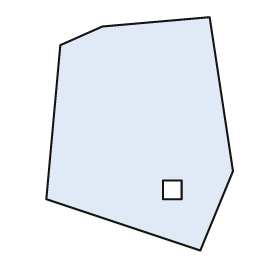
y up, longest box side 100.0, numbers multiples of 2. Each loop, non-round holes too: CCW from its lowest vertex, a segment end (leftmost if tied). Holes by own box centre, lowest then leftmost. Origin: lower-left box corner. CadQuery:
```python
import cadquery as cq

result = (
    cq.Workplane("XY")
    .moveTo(66.0, 0.0)
    .lineTo(80.0, 34.0)
    .lineTo(70.0, 100.0)
    .lineTo(24.0, 96.0)
    .lineTo(6.0, 88.0)
    .lineTo(0.0, 22.0)
    .close()
    .moveTo(50.0, 22.0)
    .lineTo(58.0, 22.0)
    .lineTo(58.0, 30.0)
    .lineTo(50.0, 30.0)
    .close()
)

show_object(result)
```